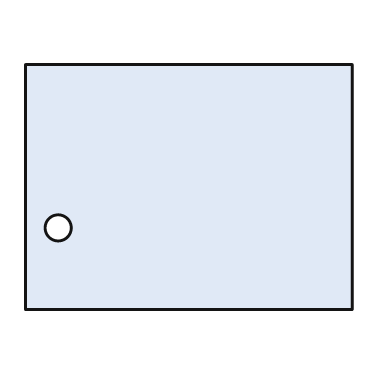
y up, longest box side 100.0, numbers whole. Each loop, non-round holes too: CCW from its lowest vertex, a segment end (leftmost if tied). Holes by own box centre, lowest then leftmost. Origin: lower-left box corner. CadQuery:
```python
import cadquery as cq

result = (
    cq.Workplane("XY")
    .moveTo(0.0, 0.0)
    .lineTo(100.0, 0.0)
    .lineTo(100.0, 75.0)
    .lineTo(0.0, 75.0)
    .close()
    .moveTo(10.0, 25.0)
    .circle(4.0)
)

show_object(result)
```